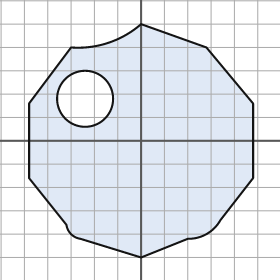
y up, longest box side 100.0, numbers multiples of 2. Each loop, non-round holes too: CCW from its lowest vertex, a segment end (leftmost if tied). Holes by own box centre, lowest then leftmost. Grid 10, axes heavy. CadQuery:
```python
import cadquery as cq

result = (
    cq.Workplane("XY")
    .moveTo(0.0, -50.0)
    .lineTo(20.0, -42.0)
    .threePointArc((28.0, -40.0), (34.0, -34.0))
    .lineTo(48.0, -16.0)
    .lineTo(48.0, 16.0)
    .lineTo(28.0, 40.0)
    .lineTo(0.0, 50.0)
    .threePointArc((-14.0, 42.0), (-30.0, 40.0))
    .lineTo(-48.0, 16.0)
    .lineTo(-48.0, -16.0)
    .lineTo(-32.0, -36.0)
    .threePointArc((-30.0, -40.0), (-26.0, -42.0))
    .close()
    .moveTo(-24.0, 18.0)
    .circle(12.0)
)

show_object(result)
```